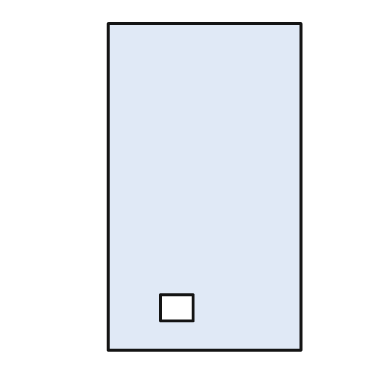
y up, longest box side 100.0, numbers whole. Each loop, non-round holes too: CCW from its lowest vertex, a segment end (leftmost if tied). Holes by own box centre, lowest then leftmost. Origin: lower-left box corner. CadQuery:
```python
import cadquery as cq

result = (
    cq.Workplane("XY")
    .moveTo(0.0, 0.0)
    .lineTo(59.0, 0.0)
    .lineTo(59.0, 100.0)
    .lineTo(0.0, 100.0)
    .close()
    .moveTo(16.0, 9.0)
    .lineTo(26.0, 9.0)
    .lineTo(26.0, 17.0)
    .lineTo(16.0, 17.0)
    .close()
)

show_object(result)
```